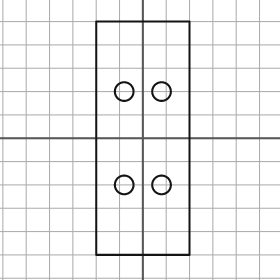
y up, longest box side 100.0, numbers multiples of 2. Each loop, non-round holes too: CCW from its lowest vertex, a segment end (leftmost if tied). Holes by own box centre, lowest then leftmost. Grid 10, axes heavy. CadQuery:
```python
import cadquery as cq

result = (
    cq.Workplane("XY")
    .moveTo(-20.0, -50.0)
    .lineTo(20.0, -50.0)
    .lineTo(20.0, 50.0)
    .lineTo(-20.0, 50.0)
    .close()
    .moveTo(-8.0, -20.0)
    .circle(4.0)
    .moveTo(8.0, -20.0)
    .circle(4.0)
    .moveTo(-8.0, 20.0)
    .circle(4.0)
    .moveTo(8.0, 20.0)
    .circle(4.0)
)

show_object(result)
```